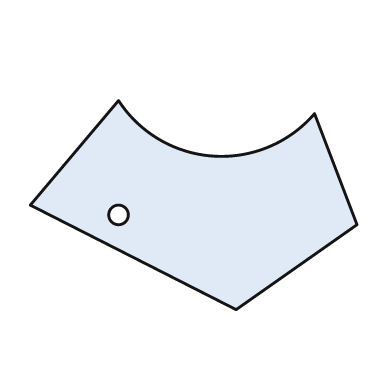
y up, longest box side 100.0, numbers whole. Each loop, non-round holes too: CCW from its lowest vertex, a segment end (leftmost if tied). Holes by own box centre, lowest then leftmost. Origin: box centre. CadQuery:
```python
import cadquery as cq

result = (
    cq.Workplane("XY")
    .moveTo(13.0, -32.0)
    .lineTo(50.0, -6.0)
    .lineTo(37.0, 28.0)
    .threePointArc((6.0, 15.0), (-23.0, 32.0))
    .lineTo(-50.0, 0.0)
    .close()
    .moveTo(-23.0, -3.0)
    .circle(3.0)
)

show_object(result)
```